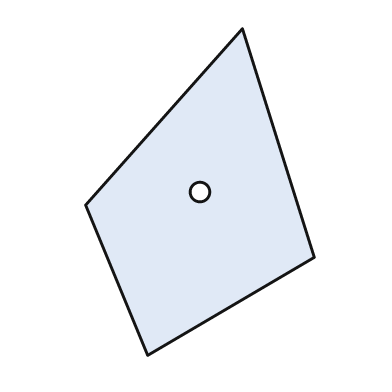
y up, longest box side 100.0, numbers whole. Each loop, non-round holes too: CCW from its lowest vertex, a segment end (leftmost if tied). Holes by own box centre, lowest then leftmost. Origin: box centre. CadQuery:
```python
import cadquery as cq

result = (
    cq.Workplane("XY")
    .moveTo(-16.0, -50.0)
    .lineTo(35.0, -20.0)
    .lineTo(13.0, 50.0)
    .lineTo(-35.0, -4.0)
    .close()
    .moveTo(0.0, 0.0)
    .circle(3.0)
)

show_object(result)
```